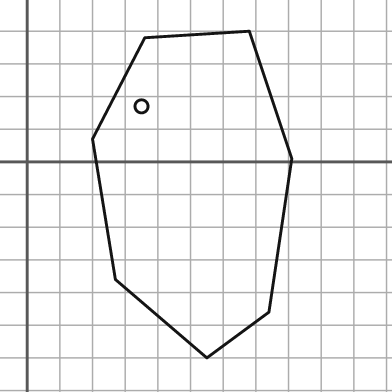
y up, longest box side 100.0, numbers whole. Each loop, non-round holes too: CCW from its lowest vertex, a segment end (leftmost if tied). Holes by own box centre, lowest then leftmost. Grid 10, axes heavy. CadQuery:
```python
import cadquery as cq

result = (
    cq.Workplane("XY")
    .moveTo(55.0, -60.0)
    .lineTo(74.0, -46.0)
    .lineTo(81.0, 1.0)
    .lineTo(68.0, 40.0)
    .lineTo(36.0, 38.0)
    .lineTo(20.0, 7.0)
    .lineTo(27.0, -36.0)
    .close()
    .moveTo(35.0, 17.0)
    .circle(2.0)
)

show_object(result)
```